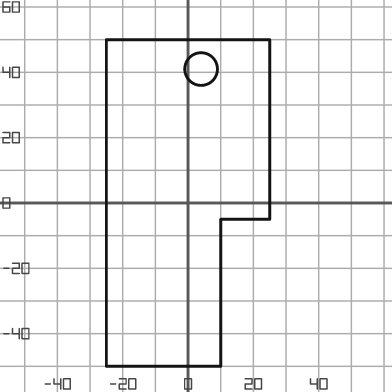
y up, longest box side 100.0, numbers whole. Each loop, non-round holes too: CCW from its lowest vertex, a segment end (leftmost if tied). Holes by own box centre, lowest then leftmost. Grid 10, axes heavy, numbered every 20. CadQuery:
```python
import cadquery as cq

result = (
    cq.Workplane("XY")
    .moveTo(-25.0, -50.0)
    .lineTo(10.0, -50.0)
    .lineTo(10.0, -5.0)
    .lineTo(25.0, -5.0)
    .lineTo(25.0, 50.0)
    .lineTo(-25.0, 50.0)
    .close()
    .moveTo(4.0, 41.0)
    .circle(5.0)
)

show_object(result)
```